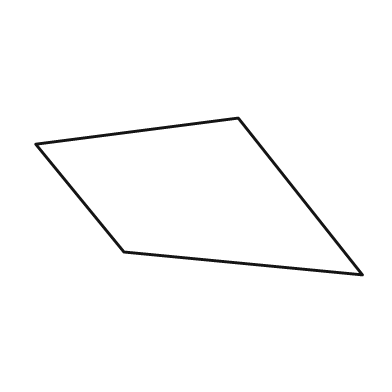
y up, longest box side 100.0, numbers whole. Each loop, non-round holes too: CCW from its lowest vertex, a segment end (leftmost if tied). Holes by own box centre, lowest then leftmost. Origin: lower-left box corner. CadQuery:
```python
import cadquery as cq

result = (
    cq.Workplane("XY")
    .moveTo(100.0, 0.0)
    .lineTo(62.0, 48.0)
    .lineTo(0.0, 40.0)
    .lineTo(27.0, 7.0)
    .close()
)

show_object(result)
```